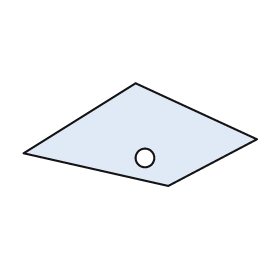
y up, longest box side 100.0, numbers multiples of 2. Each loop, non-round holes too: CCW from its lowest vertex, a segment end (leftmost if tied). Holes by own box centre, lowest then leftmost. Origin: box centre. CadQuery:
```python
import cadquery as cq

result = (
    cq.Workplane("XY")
    .moveTo(12.0, -22.0)
    .lineTo(50.0, -2.0)
    .lineTo(-2.0, 22.0)
    .lineTo(-50.0, -8.0)
    .close()
    .moveTo(2.0, -10.0)
    .circle(4.0)
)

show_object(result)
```